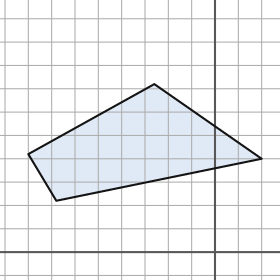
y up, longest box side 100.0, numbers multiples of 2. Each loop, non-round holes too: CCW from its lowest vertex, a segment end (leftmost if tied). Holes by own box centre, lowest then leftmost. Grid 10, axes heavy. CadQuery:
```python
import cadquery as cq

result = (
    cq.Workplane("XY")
    .moveTo(-68.0, 22.0)
    .lineTo(20.0, 40.0)
    .lineTo(-26.0, 72.0)
    .lineTo(-80.0, 42.0)
    .close()
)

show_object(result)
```